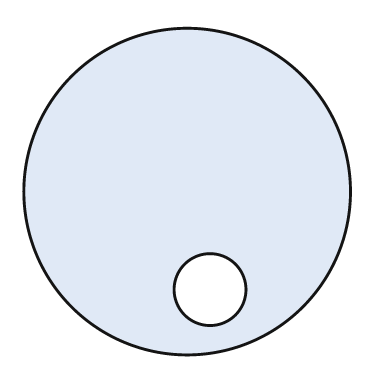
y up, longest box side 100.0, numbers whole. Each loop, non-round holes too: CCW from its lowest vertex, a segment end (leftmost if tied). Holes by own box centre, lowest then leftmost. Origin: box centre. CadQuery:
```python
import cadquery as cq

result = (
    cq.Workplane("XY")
    .moveTo(0.0, 0.0)
    .circle(50.0)
    .moveTo(7.0, -30.0)
    .circle(11.0)
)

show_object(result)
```